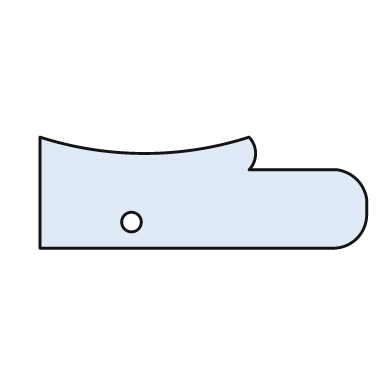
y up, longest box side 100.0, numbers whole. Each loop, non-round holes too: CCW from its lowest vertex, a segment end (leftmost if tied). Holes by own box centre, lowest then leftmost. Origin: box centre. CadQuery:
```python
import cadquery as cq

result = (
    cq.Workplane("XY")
    .moveTo(-50.0, -17.0)
    .lineTo(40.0, -17.0)
    .threePointArc((47.0, -14.0), (50.0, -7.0))
    .lineTo(50.0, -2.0)
    .threePointArc((47.0, 4.0), (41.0, 7.0))
    .lineTo(14.0, 7.0)
    .threePointArc((16.0, 12.0), (14.0, 17.0))
    .threePointArc((-18.0, 12.0), (-50.0, 17.0))
    .close()
    .moveTo(-22.0, -9.0)
    .circle(3.0)
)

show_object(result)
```